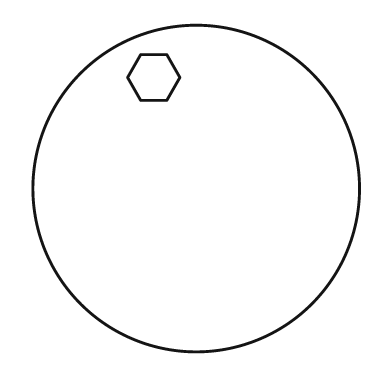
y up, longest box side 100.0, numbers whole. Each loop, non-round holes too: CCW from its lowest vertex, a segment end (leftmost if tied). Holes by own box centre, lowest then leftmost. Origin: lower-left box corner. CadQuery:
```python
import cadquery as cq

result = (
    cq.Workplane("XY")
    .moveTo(50.0, 50.0)
    .circle(50.0)
    .moveTo(33.0, 77.0)
    .lineTo(41.0, 77.0)
    .lineTo(45.0, 84.0)
    .lineTo(41.0, 91.0)
    .lineTo(33.0, 91.0)
    .lineTo(29.0, 84.0)
    .close()
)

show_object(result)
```